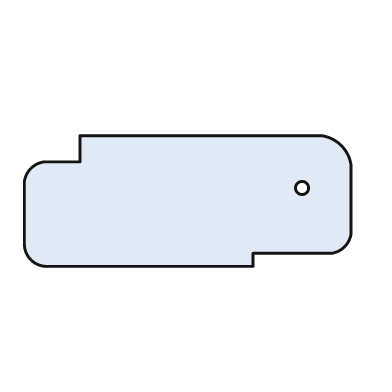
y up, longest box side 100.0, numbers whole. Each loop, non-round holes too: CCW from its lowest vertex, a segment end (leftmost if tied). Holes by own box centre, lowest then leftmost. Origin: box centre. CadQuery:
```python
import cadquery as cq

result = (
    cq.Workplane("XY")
    .moveTo(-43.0, -20.0)
    .lineTo(20.0, -20.0)
    .lineTo(20.0, -16.0)
    .lineTo(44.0, -16.0)
    .threePointArc((48.0, -14.0), (50.0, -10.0))
    .lineTo(50.0, 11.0)
    .threePointArc((47.0, 17.0), (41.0, 20.0))
    .lineTo(-33.0, 20.0)
    .lineTo(-33.0, 12.0)
    .lineTo(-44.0, 12.0)
    .threePointArc((-48.0, 10.0), (-50.0, 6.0))
    .lineTo(-50.0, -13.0)
    .threePointArc((-48.0, -18.0), (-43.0, -20.0))
    .close()
    .moveTo(35.0, 4.0)
    .circle(2.0)
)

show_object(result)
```